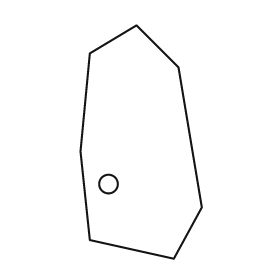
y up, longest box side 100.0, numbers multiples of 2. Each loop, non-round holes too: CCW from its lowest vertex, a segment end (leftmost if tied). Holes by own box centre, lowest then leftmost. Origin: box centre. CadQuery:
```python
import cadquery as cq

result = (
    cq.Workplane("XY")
    .moveTo(14.0, -50.0)
    .lineTo(26.0, -28.0)
    .lineTo(16.0, 32.0)
    .lineTo(-2.0, 50.0)
    .lineTo(-22.0, 38.0)
    .lineTo(-26.0, -4.0)
    .lineTo(-22.0, -42.0)
    .close()
    .moveTo(-14.0, -18.0)
    .circle(4.0)
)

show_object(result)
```